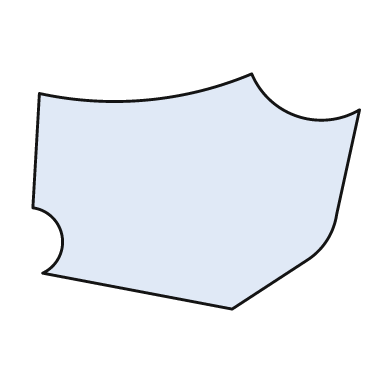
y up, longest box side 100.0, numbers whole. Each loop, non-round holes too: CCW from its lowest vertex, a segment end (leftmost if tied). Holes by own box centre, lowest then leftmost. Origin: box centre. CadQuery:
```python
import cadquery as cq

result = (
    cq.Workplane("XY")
    .moveTo(11.0, -36.0)
    .lineTo(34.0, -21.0)
    .threePointArc((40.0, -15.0), (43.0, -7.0))
    .lineTo(50.0, 25.0)
    .threePointArc((31.0, 23.0), (17.0, 36.0))
    .threePointArc((-15.0, 28.0), (-48.0, 30.0))
    .lineTo(-50.0, -5.0)
    .threePointArc((-41.0, -14.0), (-47.0, -25.0))
    .close()
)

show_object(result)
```